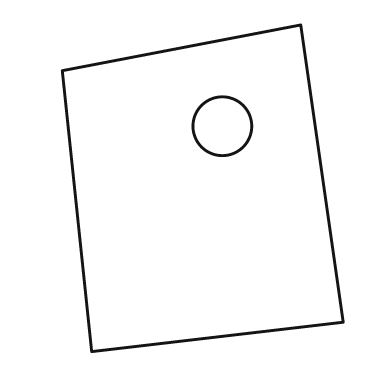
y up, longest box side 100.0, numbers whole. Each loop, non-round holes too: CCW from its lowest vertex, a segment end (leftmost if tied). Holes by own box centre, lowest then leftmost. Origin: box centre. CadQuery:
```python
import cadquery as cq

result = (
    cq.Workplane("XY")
    .moveTo(-34.0, -50.0)
    .lineTo(43.0, -41.0)
    .lineTo(30.0, 50.0)
    .lineTo(-43.0, 36.0)
    .close()
    .moveTo(6.0, 19.0)
    .circle(9.0)
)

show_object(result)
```